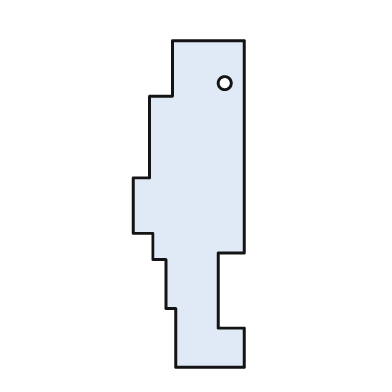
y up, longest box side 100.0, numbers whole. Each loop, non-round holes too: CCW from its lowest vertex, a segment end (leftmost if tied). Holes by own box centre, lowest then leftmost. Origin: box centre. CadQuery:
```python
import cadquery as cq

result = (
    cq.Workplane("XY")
    .moveTo(-4.0, -50.0)
    .lineTo(17.0, -50.0)
    .lineTo(17.0, -38.0)
    .lineTo(9.0, -38.0)
    .lineTo(9.0, -15.0)
    .lineTo(17.0, -15.0)
    .lineTo(17.0, 50.0)
    .lineTo(-5.0, 50.0)
    .lineTo(-5.0, 33.0)
    .lineTo(-12.0, 33.0)
    .lineTo(-12.0, 8.0)
    .lineTo(-17.0, 8.0)
    .lineTo(-17.0, -9.0)
    .lineTo(-11.0, -9.0)
    .lineTo(-11.0, -17.0)
    .lineTo(-7.0, -17.0)
    .lineTo(-7.0, -32.0)
    .lineTo(-4.0, -32.0)
    .close()
    .moveTo(11.0, 37.0)
    .circle(2.0)
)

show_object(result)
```